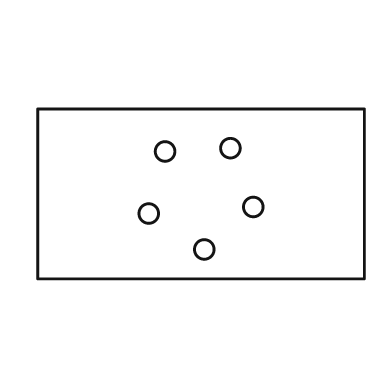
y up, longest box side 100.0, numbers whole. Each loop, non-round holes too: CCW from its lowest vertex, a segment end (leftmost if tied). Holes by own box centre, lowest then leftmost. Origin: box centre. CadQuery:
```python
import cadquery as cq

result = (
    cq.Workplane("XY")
    .moveTo(-50.0, -26.0)
    .lineTo(50.0, -26.0)
    .lineTo(50.0, 26.0)
    .lineTo(-50.0, 26.0)
    .close()
    .moveTo(1.0, -17.0)
    .circle(3.0)
    .moveTo(-16.0, -6.0)
    .circle(3.0)
    .moveTo(16.0, -4.0)
    .circle(3.0)
    .moveTo(-11.0, 13.0)
    .circle(3.0)
    .moveTo(9.0, 14.0)
    .circle(3.0)
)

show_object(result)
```